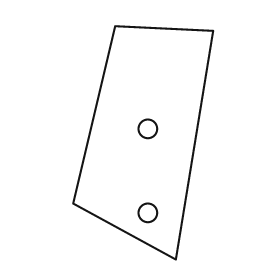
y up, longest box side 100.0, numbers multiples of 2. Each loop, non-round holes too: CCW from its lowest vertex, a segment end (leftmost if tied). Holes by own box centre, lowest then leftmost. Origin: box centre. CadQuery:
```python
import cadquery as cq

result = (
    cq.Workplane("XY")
    .moveTo(14.0, -50.0)
    .lineTo(30.0, 48.0)
    .lineTo(-12.0, 50.0)
    .lineTo(-30.0, -26.0)
    .close()
    .moveTo(2.0, -30.0)
    .circle(4.0)
    .moveTo(2.0, 6.0)
    .circle(4.0)
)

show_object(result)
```